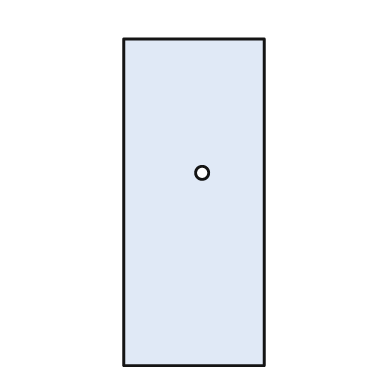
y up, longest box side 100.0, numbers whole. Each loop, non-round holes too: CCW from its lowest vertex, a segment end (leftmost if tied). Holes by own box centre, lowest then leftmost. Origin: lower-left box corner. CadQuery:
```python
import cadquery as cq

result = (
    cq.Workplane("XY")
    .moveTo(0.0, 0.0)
    .lineTo(43.0, 0.0)
    .lineTo(43.0, 100.0)
    .lineTo(0.0, 100.0)
    .close()
    .moveTo(24.0, 59.0)
    .circle(2.0)
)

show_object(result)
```